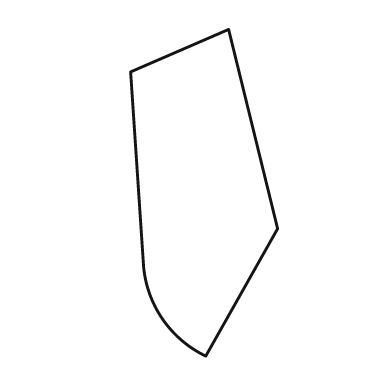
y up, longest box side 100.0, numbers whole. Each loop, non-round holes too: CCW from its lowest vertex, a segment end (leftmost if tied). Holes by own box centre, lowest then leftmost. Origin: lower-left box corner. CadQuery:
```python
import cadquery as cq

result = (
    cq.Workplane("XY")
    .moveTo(23.0, 0.0)
    .lineTo(45.0, 39.0)
    .lineTo(30.0, 100.0)
    .lineTo(0.0, 87.0)
    .lineTo(4.0, 27.0)
    .threePointArc((10.0, 11.0), (23.0, 0.0))
    .close()
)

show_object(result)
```